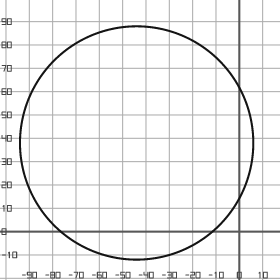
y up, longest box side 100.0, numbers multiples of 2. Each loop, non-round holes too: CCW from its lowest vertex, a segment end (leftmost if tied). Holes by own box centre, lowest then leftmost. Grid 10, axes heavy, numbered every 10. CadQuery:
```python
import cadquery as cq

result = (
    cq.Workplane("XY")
    .moveTo(-44.0, 38.0)
    .circle(50.0)
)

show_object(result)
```